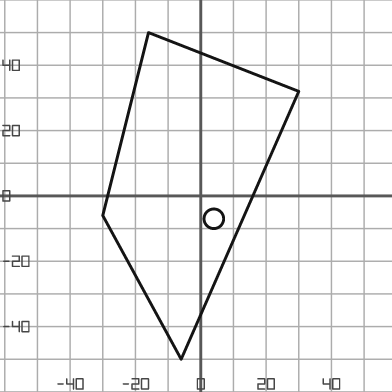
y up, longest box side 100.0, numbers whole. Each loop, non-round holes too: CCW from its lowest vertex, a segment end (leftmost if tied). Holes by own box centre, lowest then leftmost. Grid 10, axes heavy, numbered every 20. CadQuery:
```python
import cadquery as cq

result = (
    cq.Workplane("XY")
    .moveTo(-6.0, -50.0)
    .lineTo(30.0, 32.0)
    .lineTo(-16.0, 50.0)
    .lineTo(-30.0, -6.0)
    .close()
    .moveTo(4.0, -7.0)
    .circle(3.0)
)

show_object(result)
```